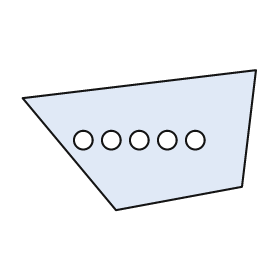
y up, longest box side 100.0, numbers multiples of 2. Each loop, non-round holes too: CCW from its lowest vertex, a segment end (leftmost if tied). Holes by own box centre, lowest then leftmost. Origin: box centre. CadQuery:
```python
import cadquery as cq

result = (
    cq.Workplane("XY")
    .moveTo(-10.0, -30.0)
    .lineTo(44.0, -20.0)
    .lineTo(50.0, 30.0)
    .lineTo(-50.0, 18.0)
    .close()
    .moveTo(-24.0, 0.0)
    .circle(4.0)
    .moveTo(-12.0, 0.0)
    .circle(4.0)
    .moveTo(0.0, 0.0)
    .circle(4.0)
    .moveTo(12.0, 0.0)
    .circle(4.0)
    .moveTo(24.0, 0.0)
    .circle(4.0)
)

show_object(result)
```